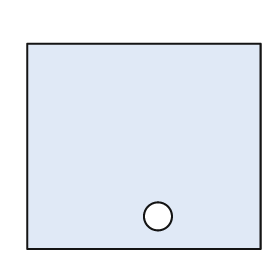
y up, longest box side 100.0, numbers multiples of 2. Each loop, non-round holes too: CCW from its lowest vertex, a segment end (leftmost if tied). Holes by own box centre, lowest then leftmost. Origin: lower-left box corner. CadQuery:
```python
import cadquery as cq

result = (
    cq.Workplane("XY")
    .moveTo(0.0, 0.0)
    .lineTo(100.0, 0.0)
    .lineTo(100.0, 88.0)
    .lineTo(0.0, 88.0)
    .close()
    .moveTo(56.0, 14.0)
    .circle(6.0)
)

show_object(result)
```